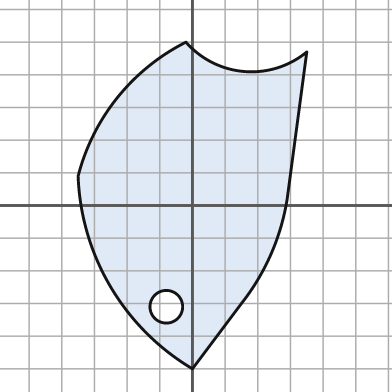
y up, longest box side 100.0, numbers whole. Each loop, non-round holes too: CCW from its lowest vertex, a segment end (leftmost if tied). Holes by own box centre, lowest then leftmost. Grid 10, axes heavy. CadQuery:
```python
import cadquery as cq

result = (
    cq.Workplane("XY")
    .moveTo(0.0, -50.0)
    .lineTo(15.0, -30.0)
    .threePointArc((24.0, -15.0), (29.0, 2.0))
    .lineTo(35.0, 47.0)
    .threePointArc((16.0, 41.0), (-2.0, 50.0))
    .threePointArc((-23.0, 33.0), (-35.0, 9.0))
    .threePointArc((-25.0, -25.0), (0.0, -50.0))
    .close()
    .moveTo(-8.0, -31.0)
    .circle(5.0)
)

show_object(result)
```